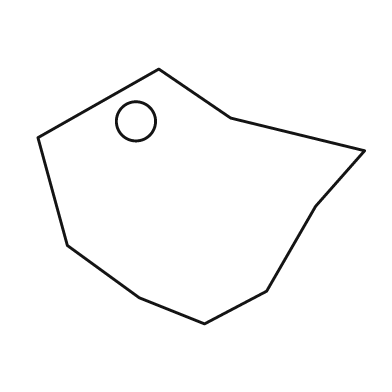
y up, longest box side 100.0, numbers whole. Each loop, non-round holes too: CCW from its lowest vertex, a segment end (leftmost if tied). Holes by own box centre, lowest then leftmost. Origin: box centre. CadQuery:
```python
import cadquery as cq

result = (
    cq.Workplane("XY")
    .moveTo(1.0, -39.0)
    .lineTo(20.0, -29.0)
    .lineTo(35.0, -3.0)
    .lineTo(50.0, 14.0)
    .lineTo(9.0, 24.0)
    .lineTo(-13.0, 39.0)
    .lineTo(-50.0, 18.0)
    .lineTo(-41.0, -15.0)
    .lineTo(-19.0, -31.0)
    .close()
    .moveTo(-20.0, 23.0)
    .circle(6.0)
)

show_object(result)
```